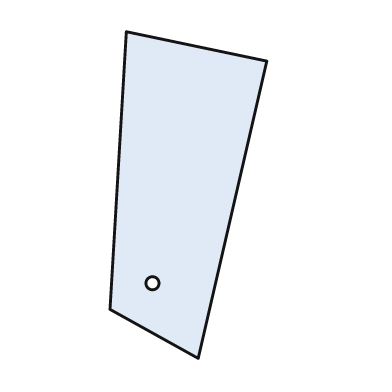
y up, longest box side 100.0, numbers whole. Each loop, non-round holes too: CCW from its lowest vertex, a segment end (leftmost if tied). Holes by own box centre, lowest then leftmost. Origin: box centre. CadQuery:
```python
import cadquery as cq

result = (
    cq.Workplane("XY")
    .moveTo(3.0, -50.0)
    .lineTo(24.0, 41.0)
    .lineTo(-19.0, 50.0)
    .lineTo(-24.0, -35.0)
    .close()
    .moveTo(-11.0, -27.0)
    .circle(2.0)
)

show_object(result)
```